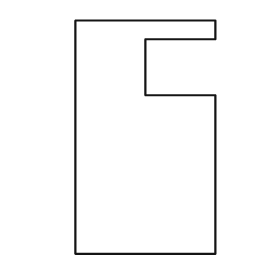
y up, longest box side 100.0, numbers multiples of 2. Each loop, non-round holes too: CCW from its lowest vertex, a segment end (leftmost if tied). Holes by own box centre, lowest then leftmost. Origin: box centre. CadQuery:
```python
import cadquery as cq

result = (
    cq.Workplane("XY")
    .moveTo(-30.0, -50.0)
    .lineTo(30.0, -50.0)
    .lineTo(30.0, 18.0)
    .lineTo(0.0, 18.0)
    .lineTo(0.0, 42.0)
    .lineTo(30.0, 42.0)
    .lineTo(30.0, 50.0)
    .lineTo(-30.0, 50.0)
    .close()
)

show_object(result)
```